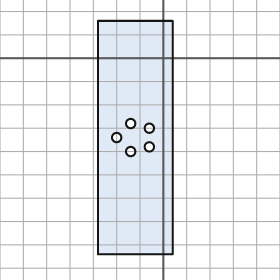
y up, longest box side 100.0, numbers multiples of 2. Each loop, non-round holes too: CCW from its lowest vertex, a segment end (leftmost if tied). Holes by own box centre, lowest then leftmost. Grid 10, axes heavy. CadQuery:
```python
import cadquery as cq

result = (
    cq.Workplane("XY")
    .moveTo(-28.0, -84.0)
    .lineTo(4.0, -84.0)
    .lineTo(4.0, 16.0)
    .lineTo(-28.0, 16.0)
    .close()
    .moveTo(-14.0, -40.0)
    .circle(2.0)
    .moveTo(-6.0, -38.0)
    .circle(2.0)
    .moveTo(-20.0, -34.0)
    .circle(2.0)
    .moveTo(-6.0, -30.0)
    .circle(2.0)
    .moveTo(-14.0, -28.0)
    .circle(2.0)
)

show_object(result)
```